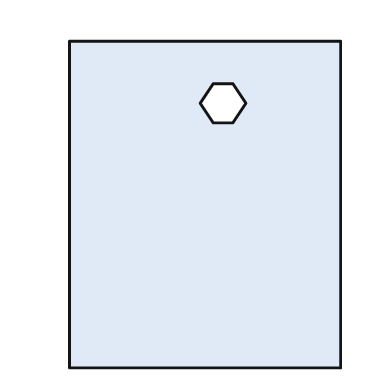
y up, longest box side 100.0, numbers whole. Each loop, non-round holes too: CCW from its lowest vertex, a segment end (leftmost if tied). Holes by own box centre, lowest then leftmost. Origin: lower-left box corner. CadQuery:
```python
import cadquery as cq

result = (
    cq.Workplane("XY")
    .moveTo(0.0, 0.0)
    .lineTo(83.0, 0.0)
    .lineTo(83.0, 100.0)
    .lineTo(0.0, 100.0)
    .close()
    .moveTo(44.0, 75.0)
    .lineTo(50.0, 75.0)
    .lineTo(54.0, 81.0)
    .lineTo(50.0, 87.0)
    .lineTo(44.0, 87.0)
    .lineTo(40.0, 81.0)
    .close()
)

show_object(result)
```